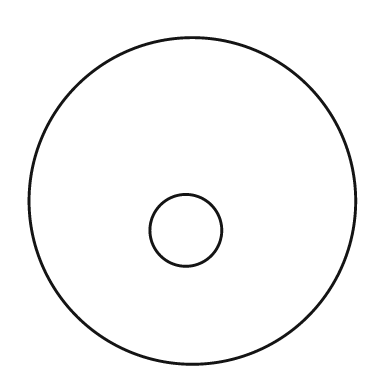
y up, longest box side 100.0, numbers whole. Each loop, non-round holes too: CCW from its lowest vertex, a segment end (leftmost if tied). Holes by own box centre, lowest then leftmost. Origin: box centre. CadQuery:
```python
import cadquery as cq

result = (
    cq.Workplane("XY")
    .moveTo(0.0, 0.0)
    .circle(50.0)
    .moveTo(-2.0, -9.0)
    .circle(11.0)
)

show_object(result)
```